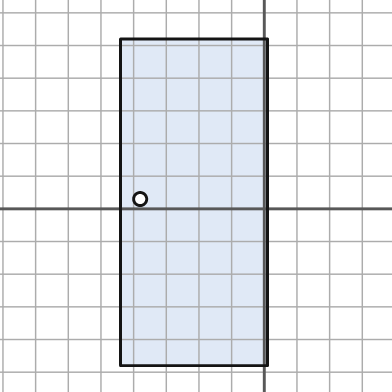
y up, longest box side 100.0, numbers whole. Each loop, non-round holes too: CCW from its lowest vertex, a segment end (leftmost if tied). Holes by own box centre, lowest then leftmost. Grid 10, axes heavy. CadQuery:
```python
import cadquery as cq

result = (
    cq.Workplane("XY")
    .moveTo(-44.0, -48.0)
    .lineTo(1.0, -48.0)
    .lineTo(1.0, 52.0)
    .lineTo(-44.0, 52.0)
    .close()
    .moveTo(-38.0, 3.0)
    .circle(2.0)
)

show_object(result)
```